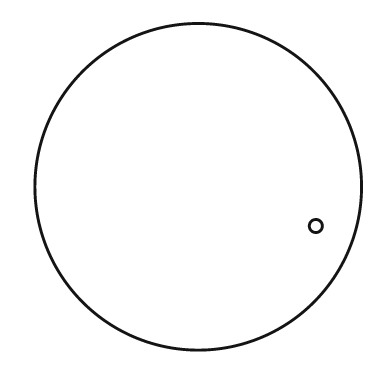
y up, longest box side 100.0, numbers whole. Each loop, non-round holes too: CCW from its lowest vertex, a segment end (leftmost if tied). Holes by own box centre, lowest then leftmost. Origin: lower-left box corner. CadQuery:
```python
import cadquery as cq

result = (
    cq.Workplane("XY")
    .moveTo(50.0, 50.0)
    .circle(50.0)
    .moveTo(86.0, 38.0)
    .circle(2.0)
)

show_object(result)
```